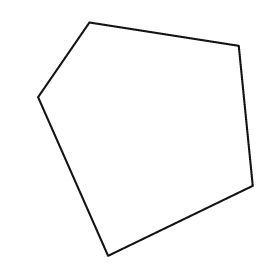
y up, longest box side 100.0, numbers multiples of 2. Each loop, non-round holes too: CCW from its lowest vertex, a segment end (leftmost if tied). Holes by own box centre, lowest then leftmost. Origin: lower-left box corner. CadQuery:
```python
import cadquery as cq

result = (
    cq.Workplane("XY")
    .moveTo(30.0, 0.0)
    .lineTo(92.0, 30.0)
    .lineTo(86.0, 90.0)
    .lineTo(22.0, 100.0)
    .lineTo(0.0, 68.0)
    .close()
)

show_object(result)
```